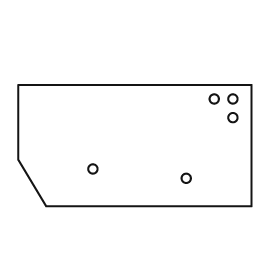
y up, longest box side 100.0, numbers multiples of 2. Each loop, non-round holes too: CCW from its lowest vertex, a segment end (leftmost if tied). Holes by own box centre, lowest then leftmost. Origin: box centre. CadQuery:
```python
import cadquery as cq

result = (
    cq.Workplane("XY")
    .moveTo(-38.0, -26.0)
    .lineTo(50.0, -26.0)
    .lineTo(50.0, 26.0)
    .lineTo(-50.0, 26.0)
    .lineTo(-50.0, -6.0)
    .close()
    .moveTo(22.0, -14.0)
    .circle(2.0)
    .moveTo(-18.0, -10.0)
    .circle(2.0)
    .moveTo(42.0, 12.0)
    .circle(2.0)
    .moveTo(34.0, 20.0)
    .circle(2.0)
    .moveTo(42.0, 20.0)
    .circle(2.0)
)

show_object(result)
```